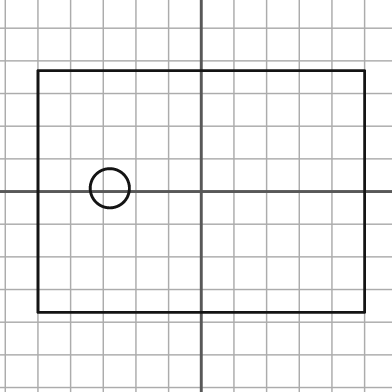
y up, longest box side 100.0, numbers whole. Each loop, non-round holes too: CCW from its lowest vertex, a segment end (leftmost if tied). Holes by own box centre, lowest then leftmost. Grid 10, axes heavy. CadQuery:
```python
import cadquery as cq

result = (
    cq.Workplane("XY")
    .moveTo(-50.0, -37.0)
    .lineTo(50.0, -37.0)
    .lineTo(50.0, 37.0)
    .lineTo(-50.0, 37.0)
    .close()
    .moveTo(-28.0, 1.0)
    .circle(6.0)
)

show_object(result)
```